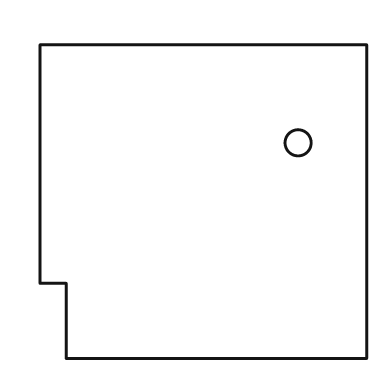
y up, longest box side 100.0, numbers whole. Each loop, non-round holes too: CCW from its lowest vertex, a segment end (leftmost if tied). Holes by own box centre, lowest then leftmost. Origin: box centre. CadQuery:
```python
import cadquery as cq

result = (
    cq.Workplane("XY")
    .moveTo(-42.0, -48.0)
    .lineTo(50.0, -48.0)
    .lineTo(50.0, 48.0)
    .lineTo(-50.0, 48.0)
    .lineTo(-50.0, -25.0)
    .lineTo(-42.0, -25.0)
    .close()
    .moveTo(29.0, 18.0)
    .circle(4.0)
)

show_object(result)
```